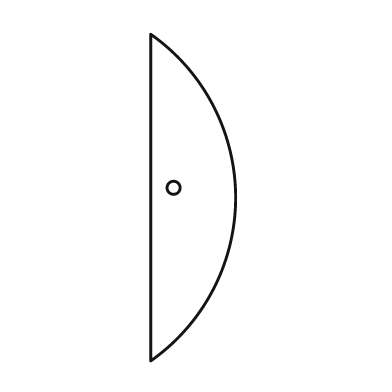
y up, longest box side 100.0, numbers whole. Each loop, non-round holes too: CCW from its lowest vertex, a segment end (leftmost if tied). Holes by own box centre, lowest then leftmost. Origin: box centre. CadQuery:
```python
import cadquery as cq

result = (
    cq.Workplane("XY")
    .moveTo(-13.0, -50.0)
    .threePointArc((13.0, 0.0), (-13.0, 50.0))
    .close()
    .moveTo(-6.0, 3.0)
    .circle(2.0)
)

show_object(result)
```